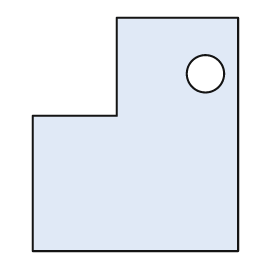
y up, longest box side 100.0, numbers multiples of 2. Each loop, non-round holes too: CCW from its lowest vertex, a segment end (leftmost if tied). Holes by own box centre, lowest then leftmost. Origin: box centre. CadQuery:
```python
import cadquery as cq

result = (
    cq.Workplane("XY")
    .moveTo(-44.0, -50.0)
    .lineTo(44.0, -50.0)
    .lineTo(44.0, 50.0)
    .lineTo(-8.0, 50.0)
    .lineTo(-8.0, 8.0)
    .lineTo(-44.0, 8.0)
    .close()
    .moveTo(30.0, 26.0)
    .circle(8.0)
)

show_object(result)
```